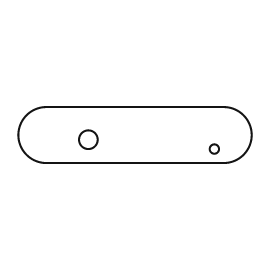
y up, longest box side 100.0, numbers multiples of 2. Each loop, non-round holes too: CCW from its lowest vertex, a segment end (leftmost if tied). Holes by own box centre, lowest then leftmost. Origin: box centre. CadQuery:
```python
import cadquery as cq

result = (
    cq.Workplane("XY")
    .moveTo(-38.0, -12.0)
    .lineTo(38.0, -12.0)
    .threePointArc((50.0, 0.0), (38.0, 12.0))
    .lineTo(-38.0, 12.0)
    .threePointArc((-50.0, 0.0), (-38.0, -12.0))
    .close()
    .moveTo(34.0, -6.0)
    .circle(2.0)
    .moveTo(-20.0, -2.0)
    .circle(4.0)
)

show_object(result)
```